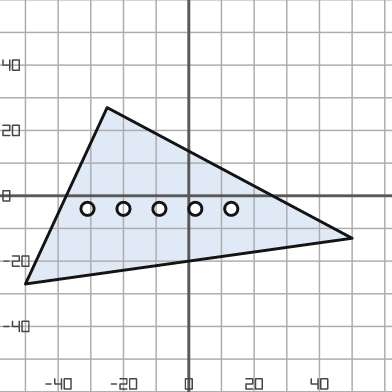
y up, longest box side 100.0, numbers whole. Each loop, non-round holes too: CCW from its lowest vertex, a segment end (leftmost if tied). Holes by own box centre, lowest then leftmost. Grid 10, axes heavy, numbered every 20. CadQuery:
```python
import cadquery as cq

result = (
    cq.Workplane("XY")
    .moveTo(-50.0, -27.0)
    .lineTo(50.0, -13.0)
    .lineTo(-25.0, 27.0)
    .close()
    .moveTo(-31.0, -4.0)
    .circle(2.0)
    .moveTo(-20.0, -4.0)
    .circle(2.0)
    .moveTo(-9.0, -4.0)
    .circle(2.0)
    .moveTo(2.0, -4.0)
    .circle(2.0)
    .moveTo(13.0, -4.0)
    .circle(2.0)
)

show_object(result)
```